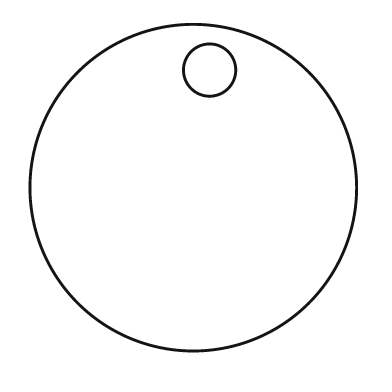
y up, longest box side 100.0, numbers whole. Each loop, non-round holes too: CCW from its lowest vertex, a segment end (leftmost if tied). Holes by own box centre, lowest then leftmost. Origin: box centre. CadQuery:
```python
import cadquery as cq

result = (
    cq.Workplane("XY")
    .moveTo(0.0, 0.0)
    .circle(50.0)
    .moveTo(5.0, 36.0)
    .circle(8.0)
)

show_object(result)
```